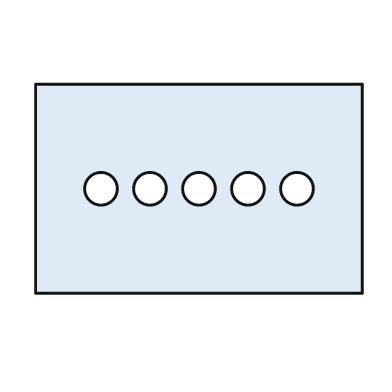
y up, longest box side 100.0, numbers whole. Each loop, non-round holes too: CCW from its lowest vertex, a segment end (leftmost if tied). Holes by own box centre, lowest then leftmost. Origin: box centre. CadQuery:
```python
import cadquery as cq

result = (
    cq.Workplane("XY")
    .moveTo(-50.0, -32.0)
    .lineTo(50.0, -32.0)
    .lineTo(50.0, 32.0)
    .lineTo(-50.0, 32.0)
    .close()
    .moveTo(-30.0, 0.0)
    .circle(5.0)
    .moveTo(-15.0, 0.0)
    .circle(5.0)
    .moveTo(0.0, 0.0)
    .circle(5.0)
    .moveTo(15.0, 0.0)
    .circle(5.0)
    .moveTo(30.0, 0.0)
    .circle(5.0)
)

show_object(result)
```